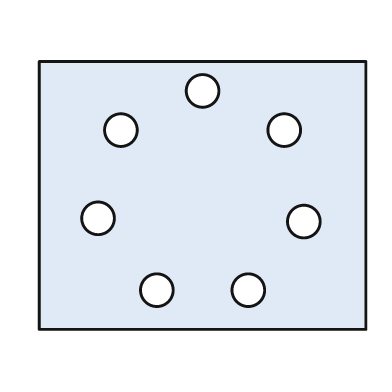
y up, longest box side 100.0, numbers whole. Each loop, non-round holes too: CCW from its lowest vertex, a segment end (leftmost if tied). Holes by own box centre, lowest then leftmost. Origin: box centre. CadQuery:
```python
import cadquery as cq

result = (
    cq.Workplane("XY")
    .moveTo(-50.0, -41.0)
    .lineTo(50.0, -41.0)
    .lineTo(50.0, 41.0)
    .lineTo(-50.0, 41.0)
    .close()
    .moveTo(-14.0, -29.0)
    .circle(5.0)
    .moveTo(14.0, -29.0)
    .circle(5.0)
    .moveTo(31.0, -8.0)
    .circle(5.0)
    .moveTo(-32.0, -7.0)
    .circle(5.0)
    .moveTo(-25.0, 20.0)
    .circle(5.0)
    .moveTo(25.0, 20.0)
    .circle(5.0)
    .moveTo(0.0, 32.0)
    .circle(5.0)
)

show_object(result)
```